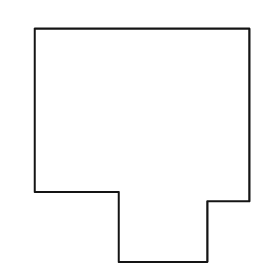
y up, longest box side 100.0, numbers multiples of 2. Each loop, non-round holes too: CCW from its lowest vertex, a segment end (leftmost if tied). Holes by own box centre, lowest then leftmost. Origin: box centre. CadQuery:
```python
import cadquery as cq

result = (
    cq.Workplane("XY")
    .moveTo(-10.0, -50.0)
    .lineTo(28.0, -50.0)
    .lineTo(28.0, -24.0)
    .lineTo(46.0, -24.0)
    .lineTo(46.0, 50.0)
    .lineTo(-46.0, 50.0)
    .lineTo(-46.0, -20.0)
    .lineTo(-10.0, -20.0)
    .close()
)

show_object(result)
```